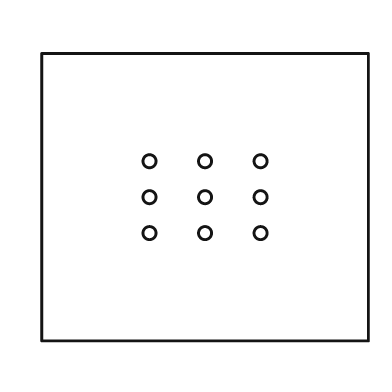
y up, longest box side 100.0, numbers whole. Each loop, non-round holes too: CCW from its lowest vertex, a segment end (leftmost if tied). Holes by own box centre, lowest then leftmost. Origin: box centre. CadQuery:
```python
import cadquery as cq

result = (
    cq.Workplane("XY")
    .moveTo(-50.0, -44.0)
    .lineTo(50.0, -44.0)
    .lineTo(50.0, 44.0)
    .lineTo(-50.0, 44.0)
    .close()
    .moveTo(-17.0, -11.0)
    .circle(2.0)
    .moveTo(0.0, -11.0)
    .circle(2.0)
    .moveTo(17.0, -11.0)
    .circle(2.0)
    .moveTo(-17.0, 0.0)
    .circle(2.0)
    .moveTo(0.0, 0.0)
    .circle(2.0)
    .moveTo(17.0, 0.0)
    .circle(2.0)
    .moveTo(-17.0, 11.0)
    .circle(2.0)
    .moveTo(0.0, 11.0)
    .circle(2.0)
    .moveTo(17.0, 11.0)
    .circle(2.0)
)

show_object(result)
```